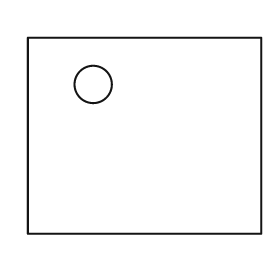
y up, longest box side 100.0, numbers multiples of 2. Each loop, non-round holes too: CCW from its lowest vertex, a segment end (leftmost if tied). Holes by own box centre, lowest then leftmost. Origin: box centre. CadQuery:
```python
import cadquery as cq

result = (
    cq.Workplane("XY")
    .moveTo(-50.0, -42.0)
    .lineTo(50.0, -42.0)
    .lineTo(50.0, 42.0)
    .lineTo(-50.0, 42.0)
    .close()
    .moveTo(-22.0, 22.0)
    .circle(8.0)
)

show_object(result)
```